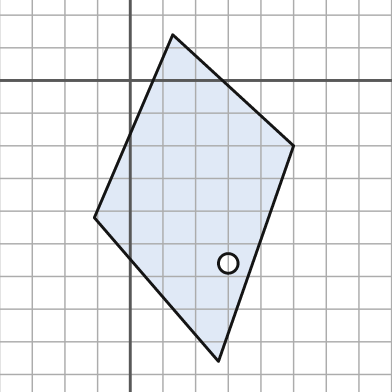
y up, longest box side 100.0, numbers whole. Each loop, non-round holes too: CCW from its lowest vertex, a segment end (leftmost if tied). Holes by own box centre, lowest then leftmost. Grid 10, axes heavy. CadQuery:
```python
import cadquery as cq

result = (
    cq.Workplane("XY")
    .moveTo(27.0, -86.0)
    .lineTo(50.0, -20.0)
    .lineTo(13.0, 14.0)
    .lineTo(-11.0, -42.0)
    .close()
    .moveTo(30.0, -56.0)
    .circle(3.0)
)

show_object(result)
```